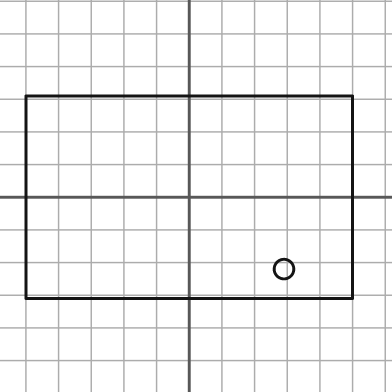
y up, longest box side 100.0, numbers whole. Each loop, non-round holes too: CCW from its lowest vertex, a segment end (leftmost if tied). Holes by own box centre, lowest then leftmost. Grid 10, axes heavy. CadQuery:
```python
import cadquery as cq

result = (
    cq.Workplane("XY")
    .moveTo(-50.0, -31.0)
    .lineTo(50.0, -31.0)
    .lineTo(50.0, 31.0)
    .lineTo(-50.0, 31.0)
    .close()
    .moveTo(29.0, -22.0)
    .circle(3.0)
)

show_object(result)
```